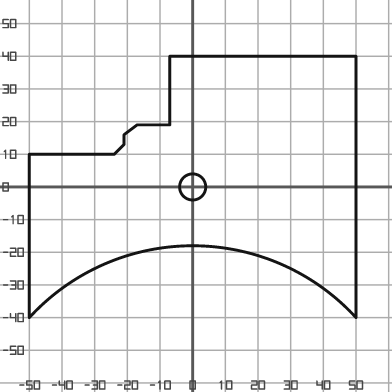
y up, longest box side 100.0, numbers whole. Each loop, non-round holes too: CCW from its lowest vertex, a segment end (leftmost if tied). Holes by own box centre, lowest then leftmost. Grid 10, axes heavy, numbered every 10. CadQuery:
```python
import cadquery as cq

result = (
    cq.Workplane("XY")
    .moveTo(-50.0, -40.0)
    .threePointArc((0.0, -18.0), (50.0, -40.0))
    .lineTo(50.0, 40.0)
    .lineTo(-7.0, 40.0)
    .lineTo(-7.0, 19.0)
    .lineTo(-17.0, 19.0)
    .lineTo(-21.0, 16.0)
    .lineTo(-21.0, 13.0)
    .lineTo(-24.0, 10.0)
    .lineTo(-50.0, 10.0)
    .close()
    .moveTo(0.0, 0.0)
    .circle(4.0)
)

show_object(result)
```